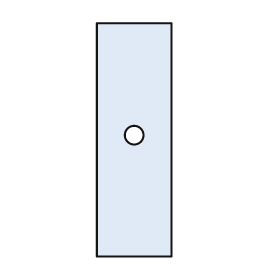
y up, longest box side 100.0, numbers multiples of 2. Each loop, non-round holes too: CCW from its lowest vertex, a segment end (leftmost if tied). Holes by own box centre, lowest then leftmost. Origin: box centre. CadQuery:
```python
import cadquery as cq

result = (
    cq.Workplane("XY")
    .moveTo(-16.0, -50.0)
    .lineTo(16.0, -50.0)
    .lineTo(16.0, 50.0)
    .lineTo(-16.0, 50.0)
    .close()
    .moveTo(0.0, 2.0)
    .circle(4.0)
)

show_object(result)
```